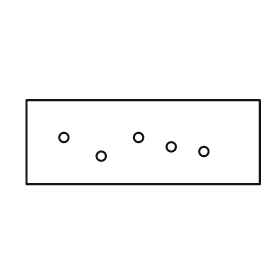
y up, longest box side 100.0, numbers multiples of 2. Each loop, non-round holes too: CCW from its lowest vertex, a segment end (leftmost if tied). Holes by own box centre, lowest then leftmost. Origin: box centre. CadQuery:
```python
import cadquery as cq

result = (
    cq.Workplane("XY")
    .moveTo(-50.0, -18.0)
    .lineTo(50.0, -18.0)
    .lineTo(50.0, 18.0)
    .lineTo(-50.0, 18.0)
    .close()
    .moveTo(-18.0, -6.0)
    .circle(2.0)
    .moveTo(26.0, -4.0)
    .circle(2.0)
    .moveTo(12.0, -2.0)
    .circle(2.0)
    .moveTo(-34.0, 2.0)
    .circle(2.0)
    .moveTo(-2.0, 2.0)
    .circle(2.0)
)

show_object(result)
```